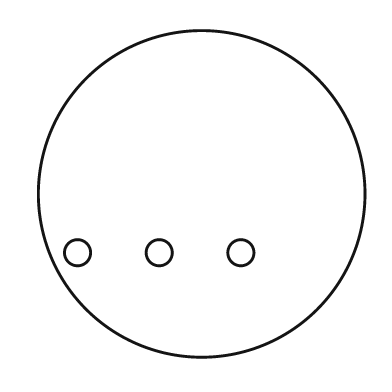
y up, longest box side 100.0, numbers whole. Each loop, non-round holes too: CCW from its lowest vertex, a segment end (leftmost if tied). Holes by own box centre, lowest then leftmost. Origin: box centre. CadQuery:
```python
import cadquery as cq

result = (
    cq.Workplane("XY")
    .moveTo(0.0, 0.0)
    .circle(50.0)
    .moveTo(-38.0, -18.0)
    .circle(4.0)
    .moveTo(-13.0, -18.0)
    .circle(4.0)
    .moveTo(12.0, -18.0)
    .circle(4.0)
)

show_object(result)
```